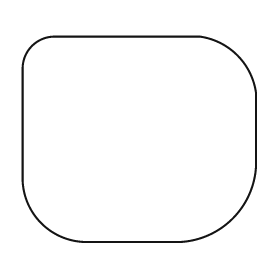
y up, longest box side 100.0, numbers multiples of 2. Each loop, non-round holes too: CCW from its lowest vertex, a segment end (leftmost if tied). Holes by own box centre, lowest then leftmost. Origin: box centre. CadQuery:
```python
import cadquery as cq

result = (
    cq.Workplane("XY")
    .moveTo(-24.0, -44.0)
    .lineTo(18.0, -44.0)
    .threePointArc((40.0, -34.0), (50.0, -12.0))
    .lineTo(50.0, 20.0)
    .threePointArc((42.0, 36.0), (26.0, 44.0))
    .lineTo(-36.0, 44.0)
    .threePointArc((-46.0, 40.0), (-50.0, 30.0))
    .lineTo(-50.0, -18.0)
    .threePointArc((-42.0, -36.0), (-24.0, -44.0))
    .close()
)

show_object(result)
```